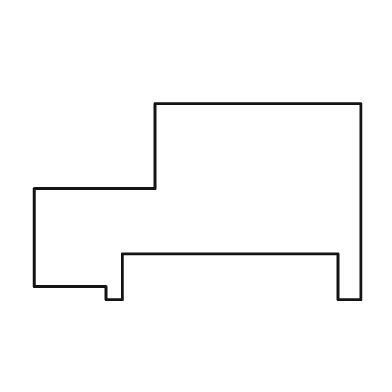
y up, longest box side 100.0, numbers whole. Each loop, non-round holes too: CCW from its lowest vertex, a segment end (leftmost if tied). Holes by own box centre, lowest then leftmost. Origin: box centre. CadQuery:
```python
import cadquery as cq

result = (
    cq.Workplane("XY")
    .moveTo(-28.0, -30.0)
    .lineTo(-23.0, -30.0)
    .lineTo(-23.0, -16.0)
    .lineTo(43.0, -16.0)
    .lineTo(43.0, -30.0)
    .lineTo(50.0, -30.0)
    .lineTo(50.0, 30.0)
    .lineTo(-13.0, 30.0)
    .lineTo(-13.0, 4.0)
    .lineTo(-50.0, 4.0)
    .lineTo(-50.0, -26.0)
    .lineTo(-28.0, -26.0)
    .close()
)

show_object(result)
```